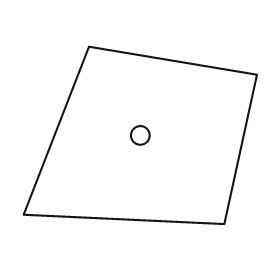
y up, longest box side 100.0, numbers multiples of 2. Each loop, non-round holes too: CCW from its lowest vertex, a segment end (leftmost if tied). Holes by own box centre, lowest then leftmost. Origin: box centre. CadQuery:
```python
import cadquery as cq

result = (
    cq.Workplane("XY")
    .moveTo(36.0, -38.0)
    .lineTo(50.0, 26.0)
    .lineTo(-22.0, 38.0)
    .lineTo(-50.0, -34.0)
    .close()
    .moveTo(0.0, 0.0)
    .circle(4.0)
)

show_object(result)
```